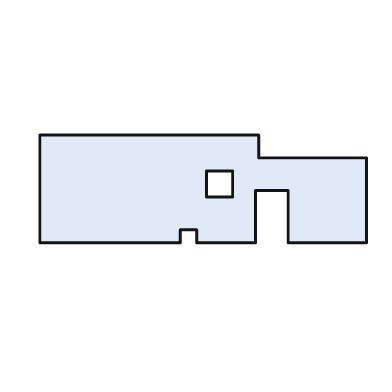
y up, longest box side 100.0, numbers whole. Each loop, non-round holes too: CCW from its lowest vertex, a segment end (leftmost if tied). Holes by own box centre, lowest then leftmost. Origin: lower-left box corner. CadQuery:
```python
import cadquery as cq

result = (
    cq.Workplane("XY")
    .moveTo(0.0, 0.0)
    .lineTo(43.0, 0.0)
    .lineTo(43.0, 4.0)
    .lineTo(48.0, 4.0)
    .lineTo(48.0, 0.0)
    .lineTo(66.0, 0.0)
    .lineTo(66.0, 16.0)
    .lineTo(76.0, 16.0)
    .lineTo(76.0, 0.0)
    .lineTo(100.0, 0.0)
    .lineTo(100.0, 26.0)
    .lineTo(67.0, 26.0)
    .lineTo(67.0, 33.0)
    .lineTo(0.0, 33.0)
    .close()
    .moveTo(51.0, 14.0)
    .lineTo(59.0, 14.0)
    .lineTo(59.0, 22.0)
    .lineTo(51.0, 22.0)
    .close()
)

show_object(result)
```